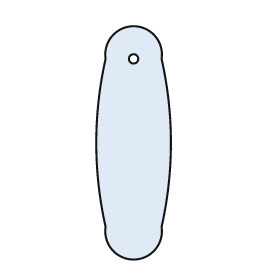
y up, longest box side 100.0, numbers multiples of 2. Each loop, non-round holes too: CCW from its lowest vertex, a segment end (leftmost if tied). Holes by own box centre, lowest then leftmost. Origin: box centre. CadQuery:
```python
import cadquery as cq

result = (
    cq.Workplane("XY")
    .moveTo(-12.0, -36.0)
    .threePointArc((0.0, -50.0), (12.0, -36.0))
    .threePointArc((16.0, 0.0), (12.0, 36.0))
    .threePointArc((0.0, 50.0), (-12.0, 36.0))
    .threePointArc((-16.0, 0.0), (-12.0, -36.0))
    .close()
    .moveTo(0.0, 36.0)
    .circle(2.0)
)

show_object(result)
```